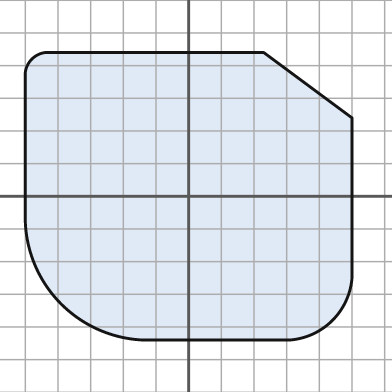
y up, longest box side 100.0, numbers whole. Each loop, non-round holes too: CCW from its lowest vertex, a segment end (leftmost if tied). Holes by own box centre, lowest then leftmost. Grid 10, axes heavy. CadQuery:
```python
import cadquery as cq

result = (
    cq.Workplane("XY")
    .moveTo(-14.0, -44.0)
    .lineTo(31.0, -44.0)
    .threePointArc((44.0, -38.0), (50.0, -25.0))
    .lineTo(50.0, 24.0)
    .lineTo(23.0, 44.0)
    .lineTo(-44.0, 44.0)
    .threePointArc((-48.0, 42.0), (-50.0, 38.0))
    .lineTo(-50.0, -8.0)
    .threePointArc((-39.0, -33.0), (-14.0, -44.0))
    .close()
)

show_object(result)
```